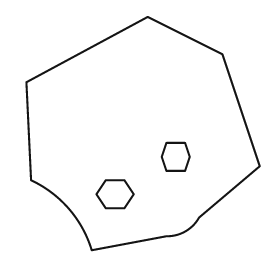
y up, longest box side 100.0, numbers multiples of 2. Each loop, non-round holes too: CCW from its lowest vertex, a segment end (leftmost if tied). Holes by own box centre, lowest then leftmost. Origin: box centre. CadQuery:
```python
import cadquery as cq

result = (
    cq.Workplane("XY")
    .moveTo(-22.0, -50.0)
    .lineTo(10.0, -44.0)
    .threePointArc((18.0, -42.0), (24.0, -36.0))
    .lineTo(50.0, -14.0)
    .lineTo(34.0, 34.0)
    .lineTo(2.0, 50.0)
    .lineTo(-50.0, 22.0)
    .lineTo(-48.0, -20.0)
    .threePointArc((-32.0, -32.0), (-22.0, -50.0))
    .close()
    .moveTo(-16.0, -32.0)
    .lineTo(-8.0, -32.0)
    .lineTo(-4.0, -26.0)
    .lineTo(-8.0, -20.0)
    .lineTo(-16.0, -20.0)
    .lineTo(-20.0, -26.0)
    .close()
    .moveTo(10.0, -16.0)
    .lineTo(18.0, -16.0)
    .lineTo(20.0, -10.0)
    .lineTo(18.0, -4.0)
    .lineTo(10.0, -4.0)
    .lineTo(8.0, -10.0)
    .close()
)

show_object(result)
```